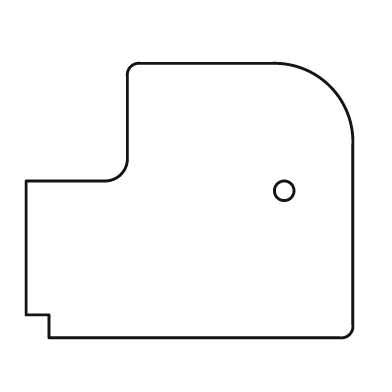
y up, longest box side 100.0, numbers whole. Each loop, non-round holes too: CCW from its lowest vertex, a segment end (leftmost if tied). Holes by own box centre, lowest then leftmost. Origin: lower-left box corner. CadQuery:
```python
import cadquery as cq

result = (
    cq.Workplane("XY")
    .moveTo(7.0, 0.0)
    .lineTo(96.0, 0.0)
    .threePointArc((99.0, 1.0), (100.0, 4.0))
    .lineTo(100.0, 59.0)
    .threePointArc((93.0, 77.0), (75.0, 84.0))
    .lineTo(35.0, 84.0)
    .threePointArc((32.0, 83.0), (31.0, 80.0))
    .lineTo(31.0, 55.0)
    .threePointArc((29.0, 50.0), (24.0, 48.0))
    .lineTo(0.0, 48.0)
    .lineTo(0.0, 7.0)
    .lineTo(7.0, 7.0)
    .close()
    .moveTo(79.0, 45.0)
    .circle(3.0)
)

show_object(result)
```